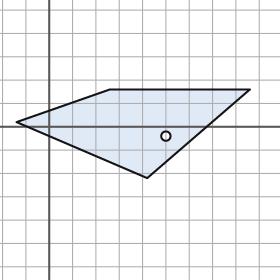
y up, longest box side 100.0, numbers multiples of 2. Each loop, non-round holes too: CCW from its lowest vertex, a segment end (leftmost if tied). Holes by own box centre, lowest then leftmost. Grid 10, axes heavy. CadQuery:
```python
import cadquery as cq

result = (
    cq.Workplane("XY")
    .moveTo(42.0, -22.0)
    .lineTo(86.0, 16.0)
    .lineTo(26.0, 16.0)
    .lineTo(-14.0, 2.0)
    .close()
    .moveTo(50.0, -4.0)
    .circle(2.0)
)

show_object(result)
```